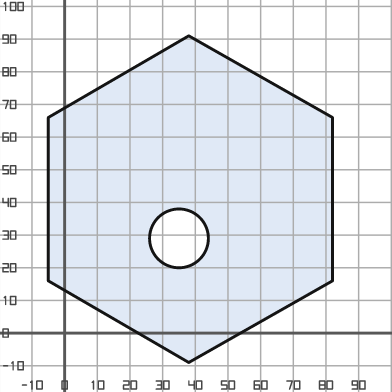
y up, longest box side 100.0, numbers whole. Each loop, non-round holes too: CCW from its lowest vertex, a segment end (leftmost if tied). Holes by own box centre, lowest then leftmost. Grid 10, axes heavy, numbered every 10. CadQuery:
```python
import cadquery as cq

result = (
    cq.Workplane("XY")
    .moveTo(38.0, -9.0)
    .lineTo(82.0, 16.0)
    .lineTo(82.0, 66.0)
    .lineTo(38.0, 91.0)
    .lineTo(-5.0, 66.0)
    .lineTo(-5.0, 16.0)
    .close()
    .moveTo(35.0, 29.0)
    .circle(9.0)
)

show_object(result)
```